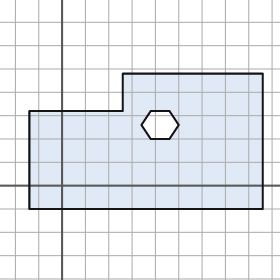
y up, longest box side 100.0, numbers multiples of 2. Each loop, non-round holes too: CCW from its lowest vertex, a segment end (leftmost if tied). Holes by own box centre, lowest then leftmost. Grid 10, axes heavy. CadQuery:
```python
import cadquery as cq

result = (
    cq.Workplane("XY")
    .moveTo(-14.0, -10.0)
    .lineTo(86.0, -10.0)
    .lineTo(86.0, 48.0)
    .lineTo(26.0, 48.0)
    .lineTo(26.0, 32.0)
    .lineTo(-14.0, 32.0)
    .close()
    .moveTo(38.0, 20.0)
    .lineTo(46.0, 20.0)
    .lineTo(50.0, 26.0)
    .lineTo(46.0, 32.0)
    .lineTo(38.0, 32.0)
    .lineTo(34.0, 26.0)
    .close()
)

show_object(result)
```